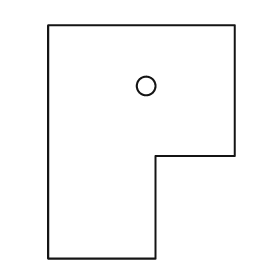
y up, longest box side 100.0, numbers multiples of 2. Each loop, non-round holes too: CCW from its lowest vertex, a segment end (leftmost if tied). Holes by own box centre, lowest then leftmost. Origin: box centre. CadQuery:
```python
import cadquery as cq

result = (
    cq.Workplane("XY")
    .moveTo(-40.0, -50.0)
    .lineTo(6.0, -50.0)
    .lineTo(6.0, -6.0)
    .lineTo(40.0, -6.0)
    .lineTo(40.0, 50.0)
    .lineTo(-40.0, 50.0)
    .close()
    .moveTo(2.0, 24.0)
    .circle(4.0)
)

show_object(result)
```